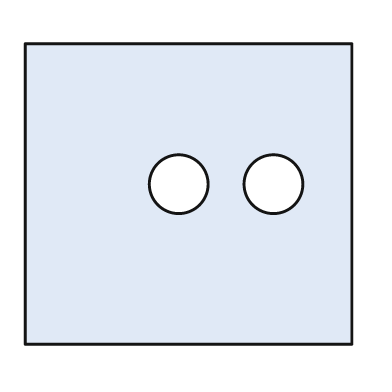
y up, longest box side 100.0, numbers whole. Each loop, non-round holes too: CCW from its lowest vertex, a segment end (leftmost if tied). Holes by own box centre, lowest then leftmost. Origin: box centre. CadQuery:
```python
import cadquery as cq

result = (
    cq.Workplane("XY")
    .moveTo(-50.0, -46.0)
    .lineTo(50.0, -46.0)
    .lineTo(50.0, 46.0)
    .lineTo(-50.0, 46.0)
    .close()
    .moveTo(-3.0, 3.0)
    .circle(9.0)
    .moveTo(26.0, 3.0)
    .circle(9.0)
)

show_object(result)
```